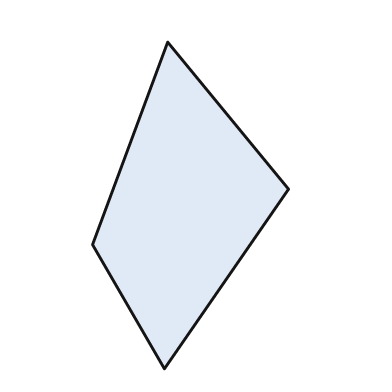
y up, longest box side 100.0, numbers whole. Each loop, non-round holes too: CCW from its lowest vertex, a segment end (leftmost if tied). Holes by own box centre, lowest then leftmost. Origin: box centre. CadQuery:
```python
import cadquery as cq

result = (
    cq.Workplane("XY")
    .moveTo(-8.0, -50.0)
    .lineTo(30.0, 5.0)
    .lineTo(-7.0, 50.0)
    .lineTo(-30.0, -12.0)
    .close()
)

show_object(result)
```